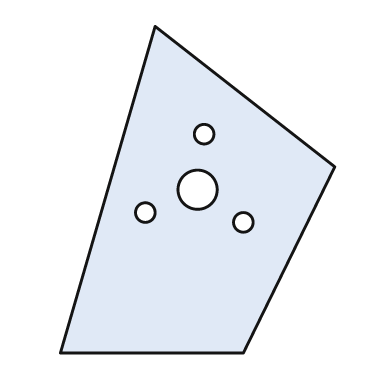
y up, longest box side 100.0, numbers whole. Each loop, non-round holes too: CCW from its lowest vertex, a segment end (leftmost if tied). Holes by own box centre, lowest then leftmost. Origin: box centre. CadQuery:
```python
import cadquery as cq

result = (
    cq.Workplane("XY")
    .moveTo(-42.0, -50.0)
    .lineTo(14.0, -50.0)
    .lineTo(42.0, 7.0)
    .lineTo(-13.0, 50.0)
    .close()
    .moveTo(14.0, -10.0)
    .circle(3.0)
    .moveTo(-16.0, -7.0)
    .circle(3.0)
    .moveTo(0.0, 0.0)
    .circle(6.0)
    .moveTo(2.0, 17.0)
    .circle(3.0)
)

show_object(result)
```